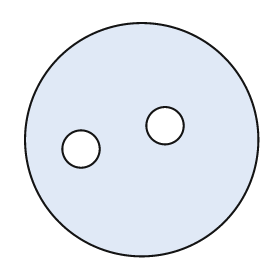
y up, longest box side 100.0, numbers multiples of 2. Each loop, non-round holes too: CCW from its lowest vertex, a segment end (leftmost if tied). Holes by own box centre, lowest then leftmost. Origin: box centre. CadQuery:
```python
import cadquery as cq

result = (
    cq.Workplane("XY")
    .moveTo(0.0, 0.0)
    .circle(50.0)
    .moveTo(-26.0, -4.0)
    .circle(8.0)
    .moveTo(10.0, 6.0)
    .circle(8.0)
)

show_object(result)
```